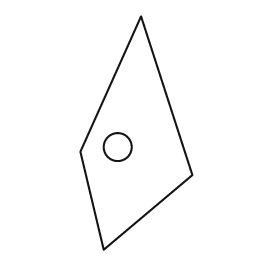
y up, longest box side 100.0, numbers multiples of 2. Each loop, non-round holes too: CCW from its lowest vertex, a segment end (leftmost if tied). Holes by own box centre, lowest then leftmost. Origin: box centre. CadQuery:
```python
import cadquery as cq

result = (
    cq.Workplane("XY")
    .moveTo(-14.0, -50.0)
    .lineTo(24.0, -18.0)
    .lineTo(2.0, 50.0)
    .lineTo(-24.0, -8.0)
    .close()
    .moveTo(-8.0, -6.0)
    .circle(6.0)
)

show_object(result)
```